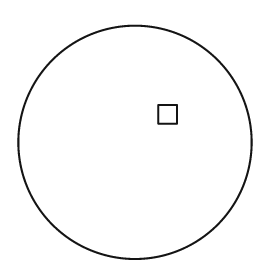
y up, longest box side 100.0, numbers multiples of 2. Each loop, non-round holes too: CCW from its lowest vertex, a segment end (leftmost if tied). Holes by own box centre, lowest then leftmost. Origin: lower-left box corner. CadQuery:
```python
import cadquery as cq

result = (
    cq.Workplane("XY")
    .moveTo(50.0, 50.0)
    .circle(50.0)
    .moveTo(60.0, 58.0)
    .lineTo(68.0, 58.0)
    .lineTo(68.0, 66.0)
    .lineTo(60.0, 66.0)
    .close()
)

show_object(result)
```